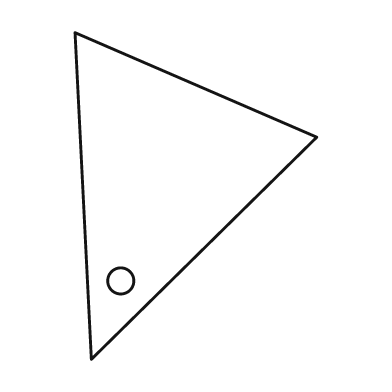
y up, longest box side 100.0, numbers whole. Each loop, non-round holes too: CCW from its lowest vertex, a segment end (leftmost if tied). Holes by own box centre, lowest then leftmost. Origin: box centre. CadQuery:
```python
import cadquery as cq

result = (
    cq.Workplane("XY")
    .moveTo(-32.0, -50.0)
    .lineTo(37.0, 18.0)
    .lineTo(-37.0, 50.0)
    .close()
    .moveTo(-23.0, -26.0)
    .circle(4.0)
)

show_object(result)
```